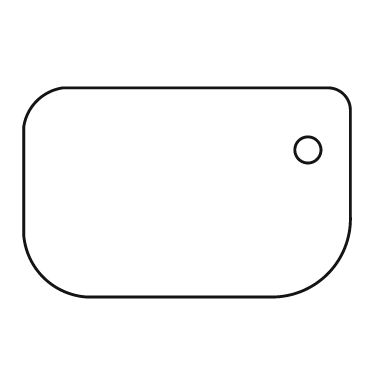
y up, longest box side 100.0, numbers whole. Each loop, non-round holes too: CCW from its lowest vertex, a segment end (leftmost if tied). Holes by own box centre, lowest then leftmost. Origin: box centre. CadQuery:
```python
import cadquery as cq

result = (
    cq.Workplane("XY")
    .moveTo(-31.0, -32.0)
    .lineTo(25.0, -32.0)
    .threePointArc((43.0, -25.0), (50.0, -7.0))
    .lineTo(50.0, 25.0)
    .threePointArc((48.0, 30.0), (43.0, 32.0))
    .lineTo(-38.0, 32.0)
    .threePointArc((-46.0, 28.0), (-50.0, 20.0))
    .lineTo(-50.0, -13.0)
    .threePointArc((-44.0, -26.0), (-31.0, -32.0))
    .close()
    .moveTo(37.0, 13.0)
    .circle(4.0)
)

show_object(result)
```